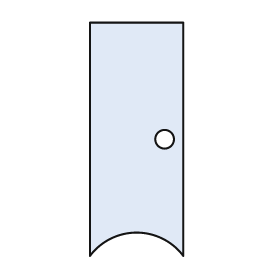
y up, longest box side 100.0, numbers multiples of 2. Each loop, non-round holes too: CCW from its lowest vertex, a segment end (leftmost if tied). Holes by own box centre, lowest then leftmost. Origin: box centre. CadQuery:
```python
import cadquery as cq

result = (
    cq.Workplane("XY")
    .moveTo(-20.0, -50.0)
    .threePointArc((0.0, -40.0), (20.0, -50.0))
    .lineTo(20.0, 50.0)
    .lineTo(-20.0, 50.0)
    .close()
    .moveTo(12.0, 0.0)
    .circle(4.0)
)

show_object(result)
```